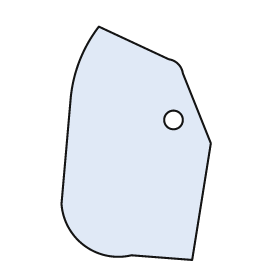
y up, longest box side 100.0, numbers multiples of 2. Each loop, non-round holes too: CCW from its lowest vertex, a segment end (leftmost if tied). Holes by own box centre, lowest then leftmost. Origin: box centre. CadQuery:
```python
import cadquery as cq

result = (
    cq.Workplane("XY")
    .moveTo(24.0, -50.0)
    .lineTo(32.0, 0.0)
    .lineTo(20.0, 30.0)
    .threePointArc((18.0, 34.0), (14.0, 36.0))
    .lineTo(-16.0, 50.0)
    .threePointArc((-24.0, 36.0), (-28.0, 20.0))
    .lineTo(-32.0, -26.0)
    .threePointArc((-22.0, -44.0), (-2.0, -48.0))
    .close()
    .moveTo(16.0, 10.0)
    .circle(4.0)
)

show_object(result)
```